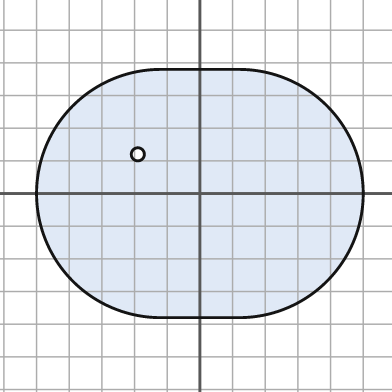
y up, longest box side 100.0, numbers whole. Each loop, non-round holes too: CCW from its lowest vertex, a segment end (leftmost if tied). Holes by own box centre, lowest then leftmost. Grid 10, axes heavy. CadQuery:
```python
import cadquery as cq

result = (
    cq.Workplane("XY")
    .moveTo(-12.0, -38.0)
    .lineTo(12.0, -38.0)
    .threePointArc((50.0, 0.0), (12.0, 38.0))
    .lineTo(-12.0, 38.0)
    .threePointArc((-50.0, 0.0), (-12.0, -38.0))
    .close()
    .moveTo(-19.0, 12.0)
    .circle(2.0)
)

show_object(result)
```